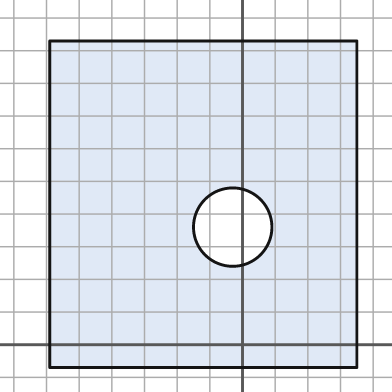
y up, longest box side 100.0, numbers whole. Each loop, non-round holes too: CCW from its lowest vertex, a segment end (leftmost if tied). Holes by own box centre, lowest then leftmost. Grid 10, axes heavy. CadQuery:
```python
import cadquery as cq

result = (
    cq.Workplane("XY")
    .moveTo(-59.0, -7.0)
    .lineTo(35.0, -7.0)
    .lineTo(35.0, 93.0)
    .lineTo(-59.0, 93.0)
    .close()
    .moveTo(-3.0, 36.0)
    .circle(12.0)
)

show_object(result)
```